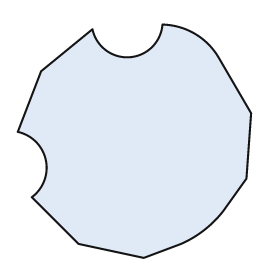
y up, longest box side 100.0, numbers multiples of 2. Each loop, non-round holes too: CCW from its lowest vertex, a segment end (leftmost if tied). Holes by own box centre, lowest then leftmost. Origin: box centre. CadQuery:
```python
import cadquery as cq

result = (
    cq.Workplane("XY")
    .moveTo(4.0, -50.0)
    .lineTo(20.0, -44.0)
    .threePointArc((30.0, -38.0), (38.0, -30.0))
    .lineTo(48.0, -16.0)
    .lineTo(50.0, 12.0)
    .lineTo(36.0, 36.0)
    .threePointArc((26.0, 46.0), (12.0, 50.0))
    .threePointArc((-2.0, 36.0), (-18.0, 48.0))
    .lineTo(-40.0, 30.0)
    .lineTo(-50.0, 4.0)
    .threePointArc((-38.0, -8.0), (-44.0, -24.0))
    .lineTo(-24.0, -44.0)
    .close()
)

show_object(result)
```